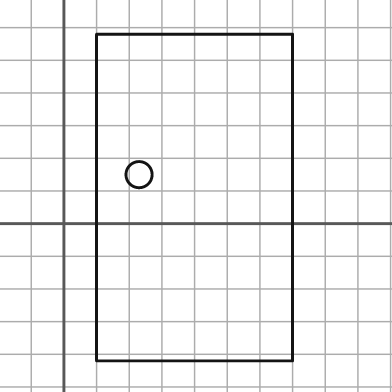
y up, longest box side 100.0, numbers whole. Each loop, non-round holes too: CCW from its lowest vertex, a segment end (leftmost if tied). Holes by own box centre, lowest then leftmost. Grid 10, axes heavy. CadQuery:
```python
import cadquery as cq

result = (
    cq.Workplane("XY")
    .moveTo(10.0, -42.0)
    .lineTo(70.0, -42.0)
    .lineTo(70.0, 58.0)
    .lineTo(10.0, 58.0)
    .close()
    .moveTo(23.0, 15.0)
    .circle(4.0)
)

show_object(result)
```